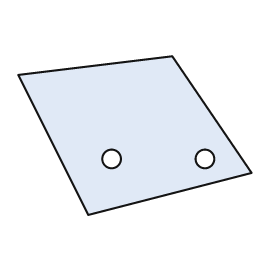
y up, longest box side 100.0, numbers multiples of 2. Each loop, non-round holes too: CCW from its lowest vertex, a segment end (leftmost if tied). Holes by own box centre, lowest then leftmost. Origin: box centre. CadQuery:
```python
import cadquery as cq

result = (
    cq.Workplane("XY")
    .moveTo(-20.0, -34.0)
    .lineTo(50.0, -16.0)
    .lineTo(16.0, 34.0)
    .lineTo(-50.0, 26.0)
    .close()
    .moveTo(-10.0, -10.0)
    .circle(4.0)
    .moveTo(30.0, -10.0)
    .circle(4.0)
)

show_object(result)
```